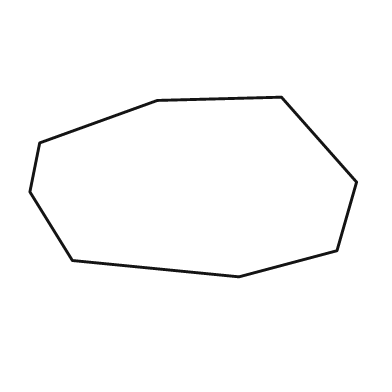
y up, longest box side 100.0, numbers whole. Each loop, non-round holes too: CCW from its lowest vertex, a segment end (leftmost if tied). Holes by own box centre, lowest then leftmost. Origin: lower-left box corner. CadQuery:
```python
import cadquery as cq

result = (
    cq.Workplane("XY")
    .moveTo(64.0, 0.0)
    .lineTo(94.0, 8.0)
    .lineTo(100.0, 29.0)
    .lineTo(77.0, 55.0)
    .lineTo(39.0, 54.0)
    .lineTo(3.0, 41.0)
    .lineTo(0.0, 26.0)
    .lineTo(13.0, 5.0)
    .close()
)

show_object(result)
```